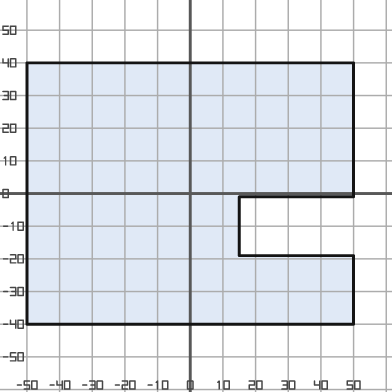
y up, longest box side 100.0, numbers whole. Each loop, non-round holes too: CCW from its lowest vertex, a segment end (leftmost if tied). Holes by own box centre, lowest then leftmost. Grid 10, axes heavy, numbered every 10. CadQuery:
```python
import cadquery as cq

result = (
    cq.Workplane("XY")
    .moveTo(-50.0, -40.0)
    .lineTo(50.0, -40.0)
    .lineTo(50.0, -19.0)
    .lineTo(15.0, -19.0)
    .lineTo(15.0, -1.0)
    .lineTo(50.0, -1.0)
    .lineTo(50.0, 40.0)
    .lineTo(-50.0, 40.0)
    .close()
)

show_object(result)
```